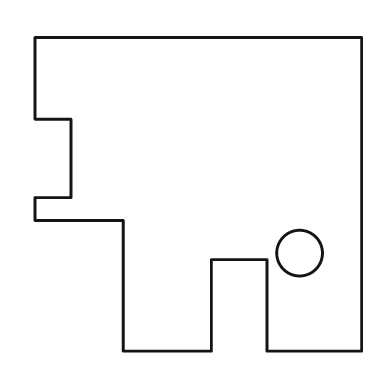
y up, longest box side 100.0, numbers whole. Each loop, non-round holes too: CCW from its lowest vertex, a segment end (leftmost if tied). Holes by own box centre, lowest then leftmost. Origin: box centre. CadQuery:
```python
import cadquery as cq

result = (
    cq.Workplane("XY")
    .moveTo(-23.0, -48.0)
    .lineTo(4.0, -48.0)
    .lineTo(4.0, -20.0)
    .lineTo(21.0, -20.0)
    .lineTo(21.0, -48.0)
    .lineTo(50.0, -48.0)
    .lineTo(50.0, 48.0)
    .lineTo(-50.0, 48.0)
    .lineTo(-50.0, 23.0)
    .lineTo(-39.0, 23.0)
    .lineTo(-39.0, -1.0)
    .lineTo(-50.0, -1.0)
    .lineTo(-50.0, -8.0)
    .lineTo(-23.0, -8.0)
    .close()
    .moveTo(31.0, -18.0)
    .circle(7.0)
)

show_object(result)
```